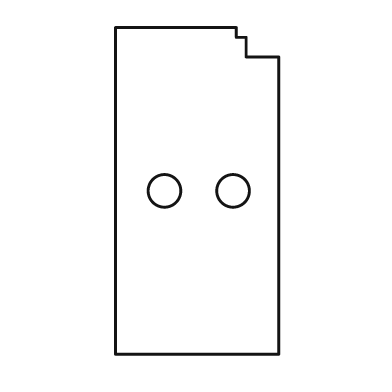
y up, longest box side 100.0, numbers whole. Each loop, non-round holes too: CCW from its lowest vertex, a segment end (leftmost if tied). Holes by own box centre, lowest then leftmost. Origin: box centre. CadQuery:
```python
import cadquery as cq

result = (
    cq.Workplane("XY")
    .moveTo(-25.0, -50.0)
    .lineTo(25.0, -50.0)
    .lineTo(25.0, 41.0)
    .lineTo(15.0, 41.0)
    .lineTo(15.0, 47.0)
    .lineTo(12.0, 47.0)
    .lineTo(12.0, 50.0)
    .lineTo(-25.0, 50.0)
    .close()
    .moveTo(-10.0, 0.0)
    .circle(5.0)
    .moveTo(11.0, 0.0)
    .circle(5.0)
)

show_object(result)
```